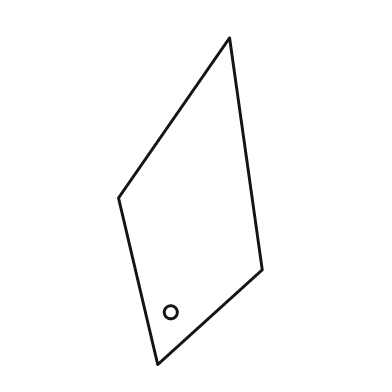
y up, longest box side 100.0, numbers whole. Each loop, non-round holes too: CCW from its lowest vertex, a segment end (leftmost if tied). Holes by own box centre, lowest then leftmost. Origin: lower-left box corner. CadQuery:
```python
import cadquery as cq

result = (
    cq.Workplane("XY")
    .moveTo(12.0, 0.0)
    .lineTo(44.0, 29.0)
    .lineTo(34.0, 100.0)
    .lineTo(0.0, 51.0)
    .close()
    .moveTo(16.0, 16.0)
    .circle(2.0)
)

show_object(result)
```